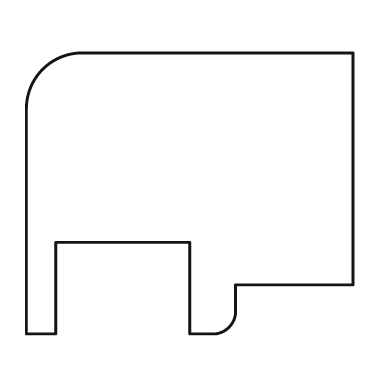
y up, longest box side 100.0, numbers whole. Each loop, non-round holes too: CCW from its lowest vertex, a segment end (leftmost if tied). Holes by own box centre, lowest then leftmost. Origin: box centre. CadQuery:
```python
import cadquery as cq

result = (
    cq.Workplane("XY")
    .moveTo(-50.0, -43.0)
    .lineTo(-41.0, -43.0)
    .lineTo(-41.0, -15.0)
    .lineTo(0.0, -15.0)
    .lineTo(0.0, -43.0)
    .lineTo(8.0, -43.0)
    .threePointArc((12.0, -41.0), (14.0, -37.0))
    .lineTo(14.0, -28.0)
    .lineTo(50.0, -28.0)
    .lineTo(50.0, 43.0)
    .lineTo(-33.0, 43.0)
    .threePointArc((-45.0, 38.0), (-50.0, 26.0))
    .close()
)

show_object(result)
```